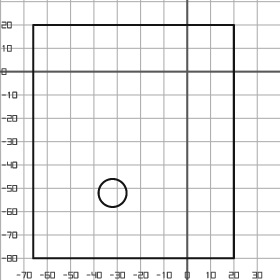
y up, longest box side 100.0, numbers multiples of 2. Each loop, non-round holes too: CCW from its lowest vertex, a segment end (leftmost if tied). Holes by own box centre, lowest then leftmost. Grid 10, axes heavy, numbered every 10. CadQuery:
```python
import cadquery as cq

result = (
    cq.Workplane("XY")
    .moveTo(-66.0, -80.0)
    .lineTo(20.0, -80.0)
    .lineTo(20.0, 20.0)
    .lineTo(-66.0, 20.0)
    .close()
    .moveTo(-32.0, -52.0)
    .circle(6.0)
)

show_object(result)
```